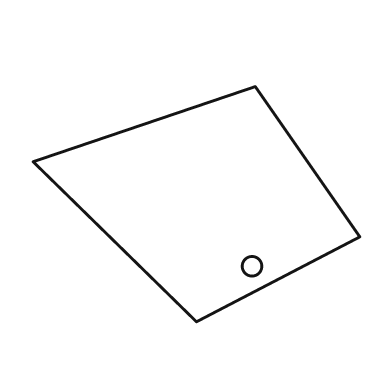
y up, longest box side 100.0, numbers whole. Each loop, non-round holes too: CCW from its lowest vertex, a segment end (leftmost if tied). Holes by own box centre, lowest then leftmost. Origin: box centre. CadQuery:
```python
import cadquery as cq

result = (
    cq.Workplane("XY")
    .moveTo(0.0, -36.0)
    .lineTo(50.0, -10.0)
    .lineTo(18.0, 36.0)
    .lineTo(-50.0, 13.0)
    .close()
    .moveTo(17.0, -19.0)
    .circle(3.0)
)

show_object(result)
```